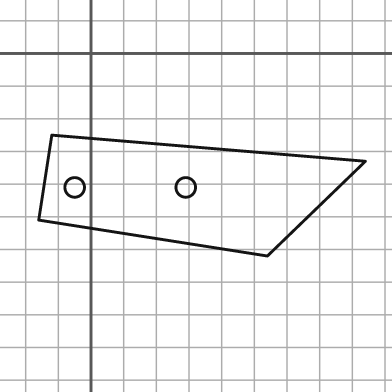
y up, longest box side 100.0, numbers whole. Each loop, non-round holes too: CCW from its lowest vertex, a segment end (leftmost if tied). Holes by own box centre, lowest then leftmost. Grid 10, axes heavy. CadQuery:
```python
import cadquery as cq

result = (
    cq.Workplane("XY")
    .moveTo(54.0, -62.0)
    .lineTo(84.0, -33.0)
    .lineTo(-12.0, -25.0)
    .lineTo(-16.0, -51.0)
    .close()
    .moveTo(-5.0, -41.0)
    .circle(3.0)
    .moveTo(29.0, -41.0)
    .circle(3.0)
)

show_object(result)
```